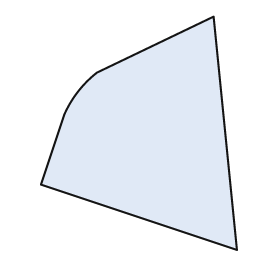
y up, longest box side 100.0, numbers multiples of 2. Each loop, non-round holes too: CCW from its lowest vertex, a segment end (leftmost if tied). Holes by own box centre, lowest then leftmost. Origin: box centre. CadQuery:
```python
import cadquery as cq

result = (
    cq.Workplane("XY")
    .moveTo(42.0, -50.0)
    .lineTo(32.0, 50.0)
    .lineTo(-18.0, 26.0)
    .threePointArc((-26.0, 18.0), (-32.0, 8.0))
    .lineTo(-42.0, -22.0)
    .close()
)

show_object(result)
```